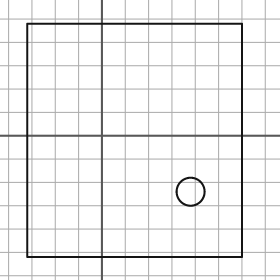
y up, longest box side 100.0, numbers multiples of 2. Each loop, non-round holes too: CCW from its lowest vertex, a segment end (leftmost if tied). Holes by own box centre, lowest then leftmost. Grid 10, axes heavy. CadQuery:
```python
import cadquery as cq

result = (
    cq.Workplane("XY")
    .moveTo(-32.0, -52.0)
    .lineTo(60.0, -52.0)
    .lineTo(60.0, 48.0)
    .lineTo(-32.0, 48.0)
    .close()
    .moveTo(38.0, -24.0)
    .circle(6.0)
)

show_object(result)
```